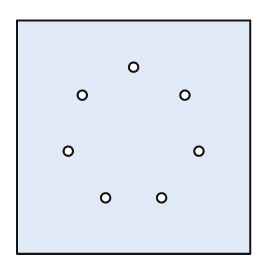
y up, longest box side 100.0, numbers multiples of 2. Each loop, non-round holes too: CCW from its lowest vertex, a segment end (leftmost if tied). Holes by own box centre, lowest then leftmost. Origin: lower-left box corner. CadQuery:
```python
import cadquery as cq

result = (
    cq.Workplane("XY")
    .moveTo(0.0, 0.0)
    .lineTo(100.0, 0.0)
    .lineTo(100.0, 100.0)
    .lineTo(0.0, 100.0)
    .close()
    .moveTo(38.0, 24.0)
    .circle(2.0)
    .moveTo(62.0, 24.0)
    .circle(2.0)
    .moveTo(22.0, 44.0)
    .circle(2.0)
    .moveTo(78.0, 44.0)
    .circle(2.0)
    .moveTo(28.0, 68.0)
    .circle(2.0)
    .moveTo(72.0, 68.0)
    .circle(2.0)
    .moveTo(50.0, 80.0)
    .circle(2.0)
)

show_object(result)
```